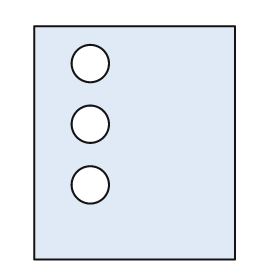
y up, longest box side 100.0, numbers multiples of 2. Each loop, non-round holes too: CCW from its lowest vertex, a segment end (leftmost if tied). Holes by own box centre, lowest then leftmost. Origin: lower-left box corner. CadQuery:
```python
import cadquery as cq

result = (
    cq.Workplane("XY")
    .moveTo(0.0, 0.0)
    .lineTo(86.0, 0.0)
    .lineTo(86.0, 100.0)
    .lineTo(0.0, 100.0)
    .close()
    .moveTo(24.0, 32.0)
    .circle(8.0)
    .moveTo(24.0, 58.0)
    .circle(8.0)
    .moveTo(24.0, 84.0)
    .circle(8.0)
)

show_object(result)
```